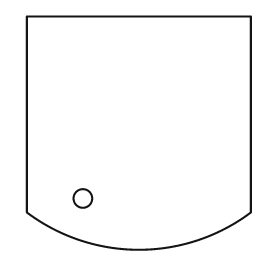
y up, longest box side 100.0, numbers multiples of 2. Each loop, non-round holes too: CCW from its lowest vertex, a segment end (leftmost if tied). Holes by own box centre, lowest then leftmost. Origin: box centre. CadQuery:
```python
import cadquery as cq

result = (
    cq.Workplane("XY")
    .moveTo(-48.0, -34.0)
    .threePointArc((0.0, -50.0), (48.0, -34.0))
    .lineTo(48.0, 50.0)
    .lineTo(-48.0, 50.0)
    .close()
    .moveTo(-24.0, -28.0)
    .circle(4.0)
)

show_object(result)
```